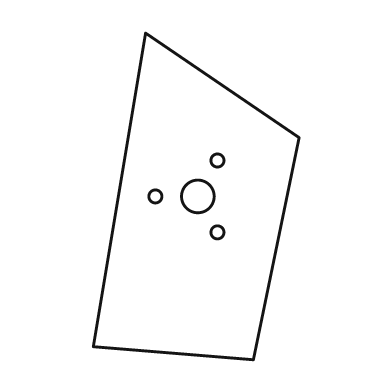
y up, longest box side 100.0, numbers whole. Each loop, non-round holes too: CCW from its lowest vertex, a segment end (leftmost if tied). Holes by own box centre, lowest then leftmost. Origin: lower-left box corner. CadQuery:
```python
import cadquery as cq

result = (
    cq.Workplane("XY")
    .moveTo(49.0, 0.0)
    .lineTo(63.0, 68.0)
    .lineTo(16.0, 100.0)
    .lineTo(0.0, 4.0)
    .close()
    .moveTo(38.0, 39.0)
    .circle(2.0)
    .moveTo(19.0, 50.0)
    .circle(2.0)
    .moveTo(32.0, 50.0)
    .circle(5.0)
    .moveTo(38.0, 61.0)
    .circle(2.0)
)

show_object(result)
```